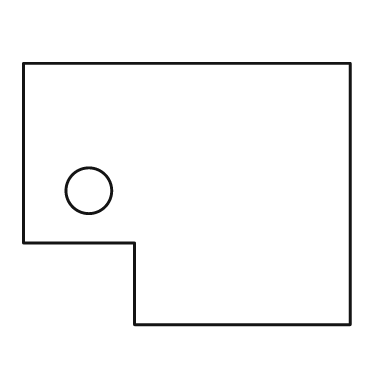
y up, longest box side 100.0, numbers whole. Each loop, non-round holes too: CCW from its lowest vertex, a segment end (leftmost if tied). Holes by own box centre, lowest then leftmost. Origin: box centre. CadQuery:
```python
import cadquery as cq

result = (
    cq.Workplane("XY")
    .moveTo(-16.0, -40.0)
    .lineTo(50.0, -40.0)
    .lineTo(50.0, 40.0)
    .lineTo(-50.0, 40.0)
    .lineTo(-50.0, -15.0)
    .lineTo(-16.0, -15.0)
    .close()
    .moveTo(-30.0, 1.0)
    .circle(7.0)
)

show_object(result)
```